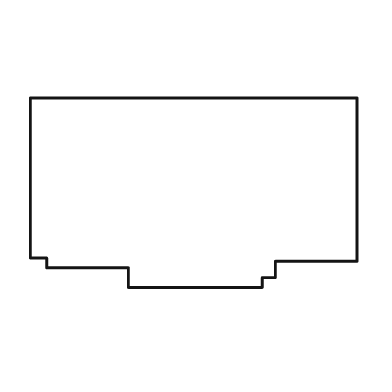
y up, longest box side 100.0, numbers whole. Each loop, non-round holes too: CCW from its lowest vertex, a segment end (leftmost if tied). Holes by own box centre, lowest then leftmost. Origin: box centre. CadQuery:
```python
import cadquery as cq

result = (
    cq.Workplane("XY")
    .moveTo(-20.0, -29.0)
    .lineTo(21.0, -29.0)
    .lineTo(21.0, -26.0)
    .lineTo(25.0, -26.0)
    .lineTo(25.0, -21.0)
    .lineTo(50.0, -21.0)
    .lineTo(50.0, 29.0)
    .lineTo(-50.0, 29.0)
    .lineTo(-50.0, -20.0)
    .lineTo(-45.0, -20.0)
    .lineTo(-45.0, -23.0)
    .lineTo(-20.0, -23.0)
    .close()
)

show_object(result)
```